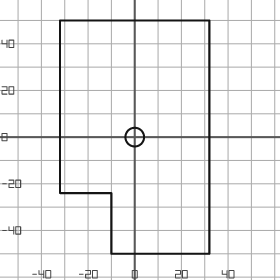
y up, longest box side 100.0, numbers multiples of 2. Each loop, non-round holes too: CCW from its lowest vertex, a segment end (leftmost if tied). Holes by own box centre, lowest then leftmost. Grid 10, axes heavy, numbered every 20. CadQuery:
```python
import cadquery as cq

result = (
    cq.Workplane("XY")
    .moveTo(-10.0, -50.0)
    .lineTo(32.0, -50.0)
    .lineTo(32.0, 50.0)
    .lineTo(-32.0, 50.0)
    .lineTo(-32.0, -24.0)
    .lineTo(-10.0, -24.0)
    .close()
    .moveTo(0.0, 0.0)
    .circle(4.0)
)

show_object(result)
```